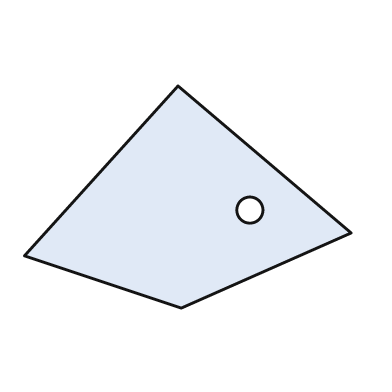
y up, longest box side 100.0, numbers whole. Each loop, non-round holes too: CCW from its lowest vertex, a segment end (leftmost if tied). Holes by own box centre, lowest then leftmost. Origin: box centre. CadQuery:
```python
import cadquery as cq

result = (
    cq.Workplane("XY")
    .moveTo(-2.0, -34.0)
    .lineTo(50.0, -11.0)
    .lineTo(-3.0, 34.0)
    .lineTo(-50.0, -18.0)
    .close()
    .moveTo(19.0, -4.0)
    .circle(4.0)
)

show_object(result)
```